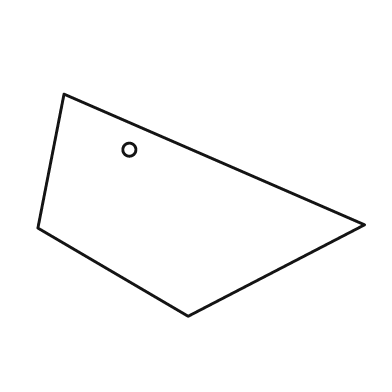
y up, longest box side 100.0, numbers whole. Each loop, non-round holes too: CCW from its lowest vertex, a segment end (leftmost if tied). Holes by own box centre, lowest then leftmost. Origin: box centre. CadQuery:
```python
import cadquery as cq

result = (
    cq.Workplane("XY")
    .moveTo(-4.0, -34.0)
    .lineTo(50.0, -6.0)
    .lineTo(-42.0, 34.0)
    .lineTo(-50.0, -7.0)
    .close()
    .moveTo(-22.0, 17.0)
    .circle(2.0)
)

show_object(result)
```